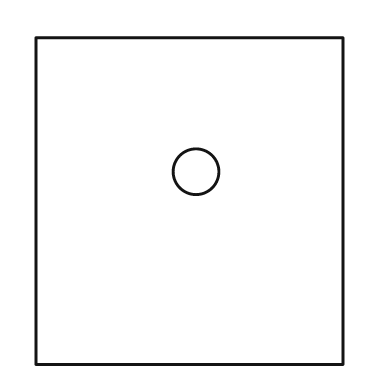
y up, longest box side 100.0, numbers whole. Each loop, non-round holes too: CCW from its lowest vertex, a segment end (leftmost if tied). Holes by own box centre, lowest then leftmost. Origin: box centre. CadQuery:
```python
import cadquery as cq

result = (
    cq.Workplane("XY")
    .moveTo(-47.0, -50.0)
    .lineTo(47.0, -50.0)
    .lineTo(47.0, 50.0)
    .lineTo(-47.0, 50.0)
    .close()
    .moveTo(2.0, 9.0)
    .circle(7.0)
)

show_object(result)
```